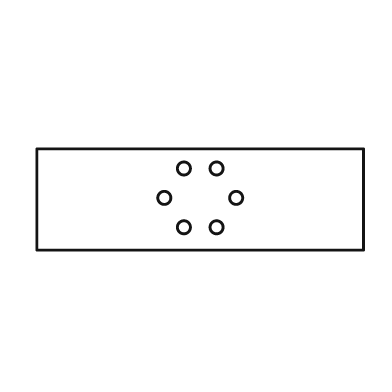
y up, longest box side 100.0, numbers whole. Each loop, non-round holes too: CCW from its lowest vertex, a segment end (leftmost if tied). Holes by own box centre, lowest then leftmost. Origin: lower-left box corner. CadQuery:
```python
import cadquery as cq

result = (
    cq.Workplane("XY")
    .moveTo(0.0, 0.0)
    .lineTo(100.0, 0.0)
    .lineTo(100.0, 31.0)
    .lineTo(0.0, 31.0)
    .close()
    .moveTo(45.0, 7.0)
    .circle(2.0)
    .moveTo(55.0, 7.0)
    .circle(2.0)
    .moveTo(39.0, 16.0)
    .circle(2.0)
    .moveTo(61.0, 16.0)
    .circle(2.0)
    .moveTo(45.0, 25.0)
    .circle(2.0)
    .moveTo(55.0, 25.0)
    .circle(2.0)
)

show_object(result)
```